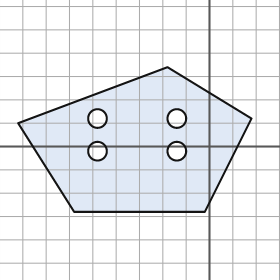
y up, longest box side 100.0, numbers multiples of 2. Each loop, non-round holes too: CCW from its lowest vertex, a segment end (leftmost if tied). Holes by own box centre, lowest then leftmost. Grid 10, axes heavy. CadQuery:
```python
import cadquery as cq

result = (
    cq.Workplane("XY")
    .moveTo(-58.0, -28.0)
    .lineTo(-2.0, -28.0)
    .lineTo(18.0, 12.0)
    .lineTo(-18.0, 34.0)
    .lineTo(-82.0, 10.0)
    .close()
    .moveTo(-48.0, -2.0)
    .circle(4.0)
    .moveTo(-14.0, -2.0)
    .circle(4.0)
    .moveTo(-48.0, 12.0)
    .circle(4.0)
    .moveTo(-14.0, 12.0)
    .circle(4.0)
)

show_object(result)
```